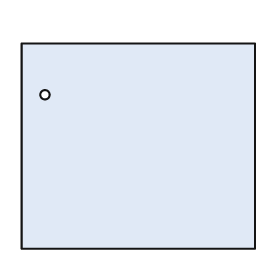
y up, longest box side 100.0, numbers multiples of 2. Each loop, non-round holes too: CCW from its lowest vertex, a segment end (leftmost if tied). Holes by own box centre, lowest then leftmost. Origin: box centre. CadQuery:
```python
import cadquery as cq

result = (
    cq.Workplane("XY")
    .moveTo(-50.0, -44.0)
    .lineTo(50.0, -44.0)
    .lineTo(50.0, 44.0)
    .lineTo(-50.0, 44.0)
    .close()
    .moveTo(-40.0, 22.0)
    .circle(2.0)
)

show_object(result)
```